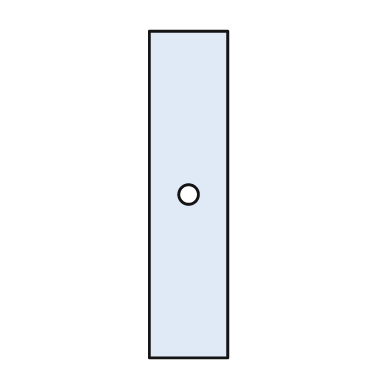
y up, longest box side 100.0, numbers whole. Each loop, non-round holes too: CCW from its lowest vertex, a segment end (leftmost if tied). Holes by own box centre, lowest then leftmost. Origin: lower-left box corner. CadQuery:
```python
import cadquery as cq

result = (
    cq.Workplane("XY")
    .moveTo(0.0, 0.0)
    .lineTo(24.0, 0.0)
    .lineTo(24.0, 100.0)
    .lineTo(0.0, 100.0)
    .close()
    .moveTo(12.0, 50.0)
    .circle(3.0)
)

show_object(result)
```